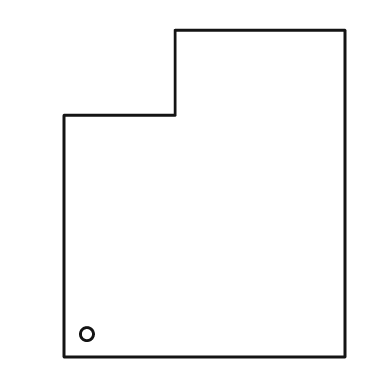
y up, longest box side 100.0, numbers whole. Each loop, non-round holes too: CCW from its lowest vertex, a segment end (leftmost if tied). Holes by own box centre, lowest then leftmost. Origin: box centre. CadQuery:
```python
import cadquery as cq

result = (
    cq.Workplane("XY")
    .moveTo(-43.0, -50.0)
    .lineTo(43.0, -50.0)
    .lineTo(43.0, 50.0)
    .lineTo(-9.0, 50.0)
    .lineTo(-9.0, 24.0)
    .lineTo(-43.0, 24.0)
    .close()
    .moveTo(-36.0, -43.0)
    .circle(2.0)
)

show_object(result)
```